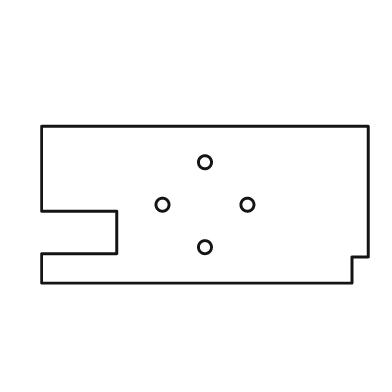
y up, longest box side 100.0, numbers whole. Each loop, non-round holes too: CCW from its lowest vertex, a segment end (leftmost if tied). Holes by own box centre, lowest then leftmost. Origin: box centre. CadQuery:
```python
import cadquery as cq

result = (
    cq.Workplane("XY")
    .moveTo(-50.0, -24.0)
    .lineTo(45.0, -24.0)
    .lineTo(45.0, -16.0)
    .lineTo(50.0, -16.0)
    .lineTo(50.0, 24.0)
    .lineTo(-50.0, 24.0)
    .lineTo(-50.0, -2.0)
    .lineTo(-27.0, -2.0)
    .lineTo(-27.0, -15.0)
    .lineTo(-50.0, -15.0)
    .close()
    .moveTo(0.0, -13.0)
    .circle(2.0)
    .moveTo(-13.0, 0.0)
    .circle(2.0)
    .moveTo(13.0, 0.0)
    .circle(2.0)
    .moveTo(0.0, 13.0)
    .circle(2.0)
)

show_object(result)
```